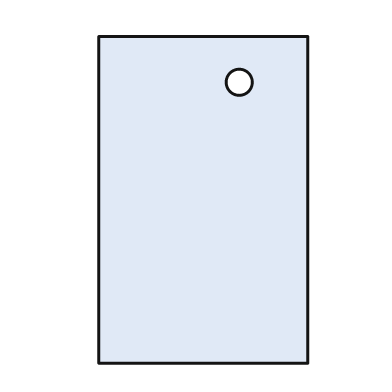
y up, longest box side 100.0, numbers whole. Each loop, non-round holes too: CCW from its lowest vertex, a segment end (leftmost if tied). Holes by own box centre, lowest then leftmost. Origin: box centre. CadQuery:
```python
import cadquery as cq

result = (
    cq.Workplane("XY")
    .moveTo(-32.0, -50.0)
    .lineTo(32.0, -50.0)
    .lineTo(32.0, 50.0)
    .lineTo(-32.0, 50.0)
    .close()
    .moveTo(11.0, 36.0)
    .circle(4.0)
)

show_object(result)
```